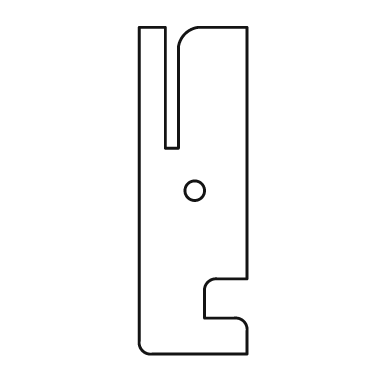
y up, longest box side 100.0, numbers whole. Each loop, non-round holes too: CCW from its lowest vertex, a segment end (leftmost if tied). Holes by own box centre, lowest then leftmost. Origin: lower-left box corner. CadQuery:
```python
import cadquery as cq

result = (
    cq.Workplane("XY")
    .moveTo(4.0, 0.0)
    .lineTo(33.0, 0.0)
    .lineTo(33.0, 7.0)
    .threePointArc((32.0, 10.0), (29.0, 11.0))
    .lineTo(20.0, 11.0)
    .lineTo(20.0, 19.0)
    .threePointArc((21.0, 22.0), (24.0, 23.0))
    .lineTo(33.0, 23.0)
    .lineTo(33.0, 100.0)
    .lineTo(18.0, 100.0)
    .threePointArc((14.0, 98.0), (12.0, 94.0))
    .lineTo(12.0, 63.0)
    .lineTo(8.0, 63.0)
    .lineTo(8.0, 100.0)
    .lineTo(0.0, 100.0)
    .lineTo(0.0, 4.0)
    .threePointArc((1.0, 1.0), (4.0, 0.0))
    .close()
    .moveTo(17.0, 50.0)
    .circle(3.0)
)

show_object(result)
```